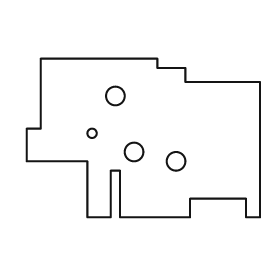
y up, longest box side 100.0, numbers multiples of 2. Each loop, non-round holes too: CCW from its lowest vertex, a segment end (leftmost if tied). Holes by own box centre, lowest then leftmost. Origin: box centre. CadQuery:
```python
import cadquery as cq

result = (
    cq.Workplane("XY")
    .moveTo(-24.0, -34.0)
    .lineTo(-14.0, -34.0)
    .lineTo(-14.0, -14.0)
    .lineTo(-10.0, -14.0)
    .lineTo(-10.0, -34.0)
    .lineTo(20.0, -34.0)
    .lineTo(20.0, -26.0)
    .lineTo(44.0, -26.0)
    .lineTo(44.0, -34.0)
    .lineTo(50.0, -34.0)
    .lineTo(50.0, 24.0)
    .lineTo(18.0, 24.0)
    .lineTo(18.0, 30.0)
    .lineTo(6.0, 30.0)
    .lineTo(6.0, 34.0)
    .lineTo(-44.0, 34.0)
    .lineTo(-44.0, 4.0)
    .lineTo(-50.0, 4.0)
    .lineTo(-50.0, -10.0)
    .lineTo(-24.0, -10.0)
    .close()
    .moveTo(14.0, -10.0)
    .circle(4.0)
    .moveTo(-4.0, -6.0)
    .circle(4.0)
    .moveTo(-22.0, 2.0)
    .circle(2.0)
    .moveTo(-12.0, 18.0)
    .circle(4.0)
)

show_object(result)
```